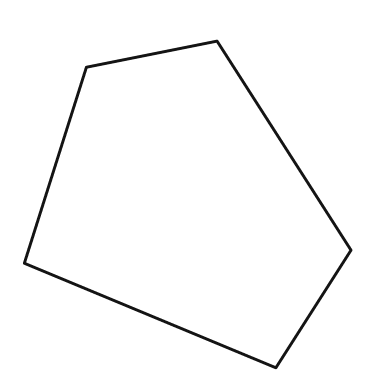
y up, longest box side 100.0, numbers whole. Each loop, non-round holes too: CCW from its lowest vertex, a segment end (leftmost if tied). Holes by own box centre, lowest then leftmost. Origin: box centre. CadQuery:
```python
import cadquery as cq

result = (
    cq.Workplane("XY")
    .moveTo(27.0, -50.0)
    .lineTo(50.0, -14.0)
    .lineTo(9.0, 50.0)
    .lineTo(-31.0, 42.0)
    .lineTo(-50.0, -18.0)
    .close()
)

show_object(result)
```